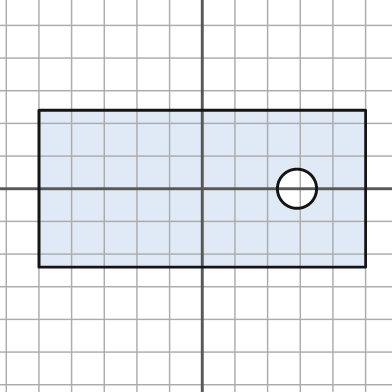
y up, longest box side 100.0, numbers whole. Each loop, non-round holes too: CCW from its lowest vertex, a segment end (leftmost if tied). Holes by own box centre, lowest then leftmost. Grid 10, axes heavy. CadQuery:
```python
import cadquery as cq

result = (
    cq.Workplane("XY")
    .moveTo(-50.0, -24.0)
    .lineTo(50.0, -24.0)
    .lineTo(50.0, 24.0)
    .lineTo(-50.0, 24.0)
    .close()
    .moveTo(29.0, 0.0)
    .circle(6.0)
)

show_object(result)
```